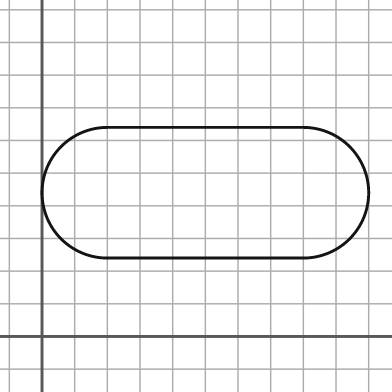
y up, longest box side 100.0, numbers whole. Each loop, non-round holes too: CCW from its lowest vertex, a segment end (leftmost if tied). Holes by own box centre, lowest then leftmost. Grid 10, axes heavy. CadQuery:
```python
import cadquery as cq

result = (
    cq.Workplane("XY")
    .moveTo(20.0, 24.0)
    .lineTo(80.0, 24.0)
    .threePointArc((100.0, 44.0), (80.0, 64.0))
    .lineTo(20.0, 64.0)
    .threePointArc((0.0, 44.0), (20.0, 24.0))
    .close()
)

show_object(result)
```